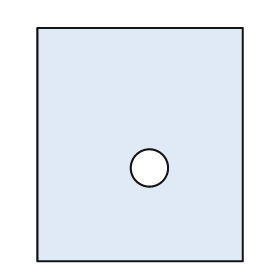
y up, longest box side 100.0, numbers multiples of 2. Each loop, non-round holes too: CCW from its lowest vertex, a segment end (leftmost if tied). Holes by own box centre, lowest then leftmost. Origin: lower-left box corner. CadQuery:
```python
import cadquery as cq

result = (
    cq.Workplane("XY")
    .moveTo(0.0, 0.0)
    .lineTo(88.0, 0.0)
    .lineTo(88.0, 100.0)
    .lineTo(0.0, 100.0)
    .close()
    .moveTo(48.0, 40.0)
    .circle(8.0)
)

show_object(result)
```